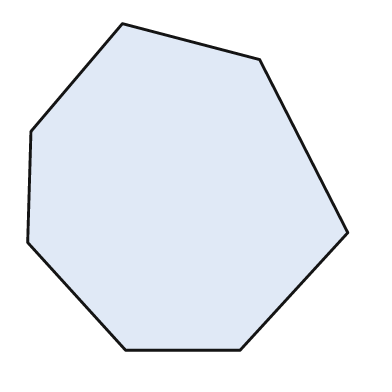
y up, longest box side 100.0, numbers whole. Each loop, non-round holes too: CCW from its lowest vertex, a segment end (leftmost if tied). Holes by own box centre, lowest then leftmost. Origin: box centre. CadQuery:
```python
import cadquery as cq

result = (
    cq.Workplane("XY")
    .moveTo(-19.0, -50.0)
    .lineTo(16.0, -50.0)
    .lineTo(49.0, -14.0)
    .lineTo(22.0, 39.0)
    .lineTo(-20.0, 50.0)
    .lineTo(-48.0, 17.0)
    .lineTo(-49.0, -17.0)
    .close()
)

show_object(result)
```